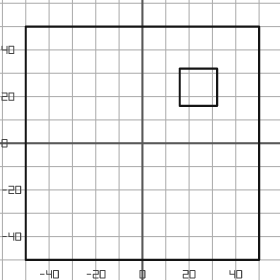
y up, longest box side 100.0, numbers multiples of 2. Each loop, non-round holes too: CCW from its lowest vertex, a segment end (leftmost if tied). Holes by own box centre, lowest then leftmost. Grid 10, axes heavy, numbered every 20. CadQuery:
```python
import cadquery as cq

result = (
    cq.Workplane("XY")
    .moveTo(-50.0, -50.0)
    .lineTo(50.0, -50.0)
    .lineTo(50.0, 50.0)
    .lineTo(-50.0, 50.0)
    .close()
    .moveTo(16.0, 16.0)
    .lineTo(32.0, 16.0)
    .lineTo(32.0, 32.0)
    .lineTo(16.0, 32.0)
    .close()
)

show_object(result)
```